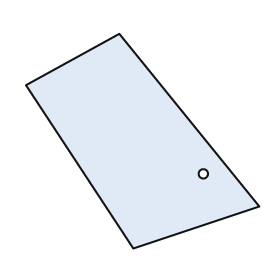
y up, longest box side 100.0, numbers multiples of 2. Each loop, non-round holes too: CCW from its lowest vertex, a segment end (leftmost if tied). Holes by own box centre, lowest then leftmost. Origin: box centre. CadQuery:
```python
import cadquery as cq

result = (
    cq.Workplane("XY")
    .moveTo(-4.0, -46.0)
    .lineTo(50.0, -28.0)
    .lineTo(-10.0, 46.0)
    .lineTo(-50.0, 24.0)
    .close()
    .moveTo(26.0, -14.0)
    .circle(2.0)
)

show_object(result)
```